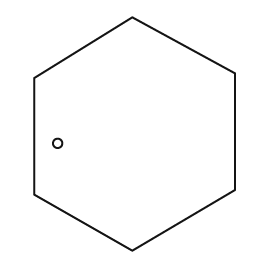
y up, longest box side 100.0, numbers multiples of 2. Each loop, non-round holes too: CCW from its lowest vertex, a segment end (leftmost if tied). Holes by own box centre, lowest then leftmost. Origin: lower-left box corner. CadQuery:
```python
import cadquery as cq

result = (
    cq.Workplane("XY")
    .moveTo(42.0, 0.0)
    .lineTo(86.0, 26.0)
    .lineTo(86.0, 76.0)
    .lineTo(42.0, 100.0)
    .lineTo(0.0, 74.0)
    .lineTo(0.0, 24.0)
    .close()
    .moveTo(10.0, 46.0)
    .circle(2.0)
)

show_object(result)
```